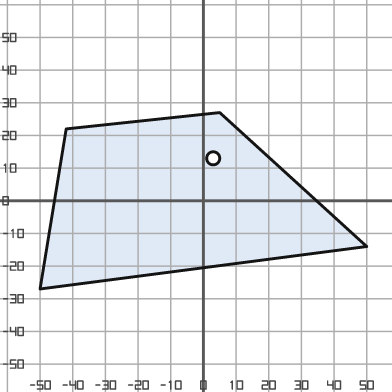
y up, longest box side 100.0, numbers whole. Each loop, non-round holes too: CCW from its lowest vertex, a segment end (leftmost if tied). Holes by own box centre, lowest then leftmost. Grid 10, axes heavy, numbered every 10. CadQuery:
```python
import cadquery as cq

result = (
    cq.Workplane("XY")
    .moveTo(-50.0, -27.0)
    .lineTo(50.0, -14.0)
    .lineTo(5.0, 27.0)
    .lineTo(-42.0, 22.0)
    .close()
    .moveTo(3.0, 13.0)
    .circle(2.0)
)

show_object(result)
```